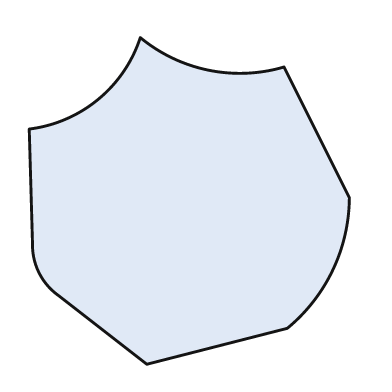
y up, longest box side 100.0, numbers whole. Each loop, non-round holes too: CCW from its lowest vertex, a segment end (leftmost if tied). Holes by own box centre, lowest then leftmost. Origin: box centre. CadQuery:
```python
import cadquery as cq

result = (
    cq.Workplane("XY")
    .moveTo(-13.0, -50.0)
    .lineTo(30.0, -39.0)
    .threePointArc((44.0, -21.0), (49.0, 1.0))
    .lineTo(29.0, 41.0)
    .threePointArc((6.0, 40.0), (-15.0, 50.0))
    .threePointArc((-28.0, 31.0), (-49.0, 22.0))
    .lineTo(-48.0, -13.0)
    .threePointArc((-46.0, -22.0), (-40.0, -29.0))
    .close()
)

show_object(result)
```